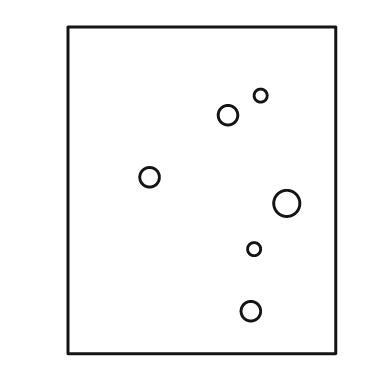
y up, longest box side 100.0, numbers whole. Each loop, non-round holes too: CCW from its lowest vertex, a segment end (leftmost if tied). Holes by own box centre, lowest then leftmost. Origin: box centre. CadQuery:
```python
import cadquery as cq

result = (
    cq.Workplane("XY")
    .moveTo(-41.0, -50.0)
    .lineTo(41.0, -50.0)
    .lineTo(41.0, 50.0)
    .lineTo(-41.0, 50.0)
    .close()
    .moveTo(15.0, -37.0)
    .circle(3.0)
    .moveTo(16.0, -18.0)
    .circle(2.0)
    .moveTo(26.0, -4.0)
    .circle(4.0)
    .moveTo(-16.0, 4.0)
    .circle(3.0)
    .moveTo(8.0, 23.0)
    .circle(3.0)
    .moveTo(18.0, 29.0)
    .circle(2.0)
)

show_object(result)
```